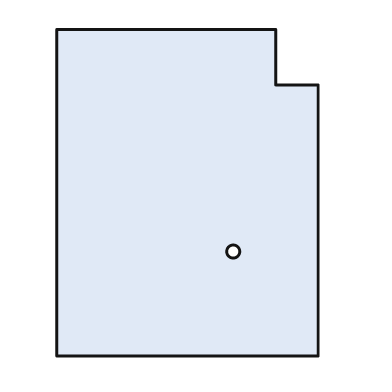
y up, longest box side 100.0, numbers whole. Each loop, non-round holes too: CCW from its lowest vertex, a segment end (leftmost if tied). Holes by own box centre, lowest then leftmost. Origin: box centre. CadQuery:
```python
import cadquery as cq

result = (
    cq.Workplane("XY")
    .moveTo(-40.0, -50.0)
    .lineTo(40.0, -50.0)
    .lineTo(40.0, 33.0)
    .lineTo(27.0, 33.0)
    .lineTo(27.0, 50.0)
    .lineTo(-40.0, 50.0)
    .close()
    .moveTo(14.0, -18.0)
    .circle(2.0)
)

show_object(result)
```